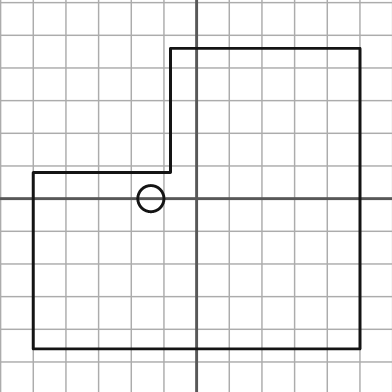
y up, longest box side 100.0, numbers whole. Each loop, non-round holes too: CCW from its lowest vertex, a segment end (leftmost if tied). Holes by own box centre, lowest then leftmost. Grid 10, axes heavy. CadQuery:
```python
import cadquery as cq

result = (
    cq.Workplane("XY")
    .moveTo(-50.0, -46.0)
    .lineTo(50.0, -46.0)
    .lineTo(50.0, 46.0)
    .lineTo(-8.0, 46.0)
    .lineTo(-8.0, 8.0)
    .lineTo(-50.0, 8.0)
    .close()
    .moveTo(-14.0, 0.0)
    .circle(4.0)
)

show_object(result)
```